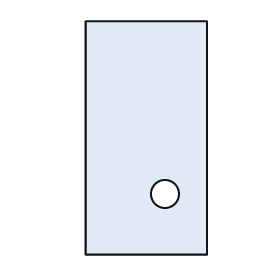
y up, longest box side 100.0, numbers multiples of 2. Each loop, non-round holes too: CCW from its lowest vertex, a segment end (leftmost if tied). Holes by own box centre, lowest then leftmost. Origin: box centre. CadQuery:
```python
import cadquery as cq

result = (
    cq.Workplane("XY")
    .moveTo(-26.0, -50.0)
    .lineTo(26.0, -50.0)
    .lineTo(26.0, 50.0)
    .lineTo(-26.0, 50.0)
    .close()
    .moveTo(8.0, -24.0)
    .circle(6.0)
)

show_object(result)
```